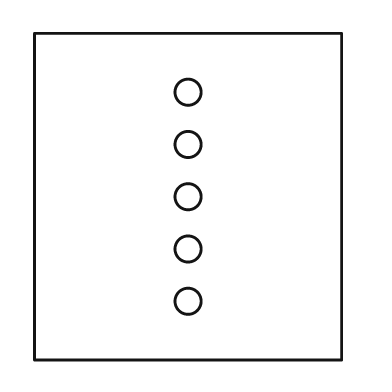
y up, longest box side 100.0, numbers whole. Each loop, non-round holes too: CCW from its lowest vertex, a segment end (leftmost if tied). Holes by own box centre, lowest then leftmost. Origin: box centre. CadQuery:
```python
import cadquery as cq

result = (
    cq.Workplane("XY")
    .moveTo(-47.0, -50.0)
    .lineTo(47.0, -50.0)
    .lineTo(47.0, 50.0)
    .lineTo(-47.0, 50.0)
    .close()
    .moveTo(0.0, -32.0)
    .circle(4.0)
    .moveTo(0.0, -16.0)
    .circle(4.0)
    .moveTo(0.0, 0.0)
    .circle(4.0)
    .moveTo(0.0, 16.0)
    .circle(4.0)
    .moveTo(0.0, 32.0)
    .circle(4.0)
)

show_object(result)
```